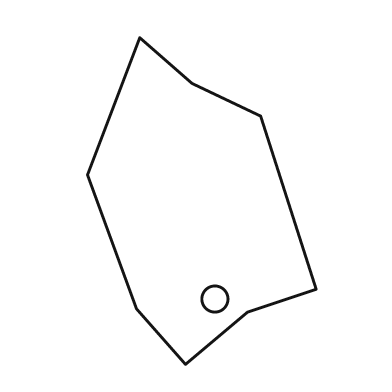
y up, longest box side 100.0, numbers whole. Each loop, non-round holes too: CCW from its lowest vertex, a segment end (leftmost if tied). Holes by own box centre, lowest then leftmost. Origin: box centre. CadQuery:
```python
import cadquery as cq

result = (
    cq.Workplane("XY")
    .moveTo(-5.0, -50.0)
    .lineTo(14.0, -34.0)
    .lineTo(35.0, -27.0)
    .lineTo(18.0, 26.0)
    .lineTo(-3.0, 36.0)
    .lineTo(-19.0, 50.0)
    .lineTo(-35.0, 8.0)
    .lineTo(-20.0, -33.0)
    .close()
    .moveTo(4.0, -30.0)
    .circle(4.0)
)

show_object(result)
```